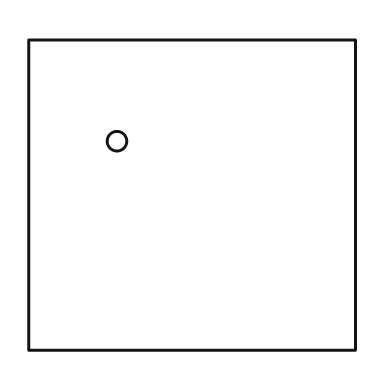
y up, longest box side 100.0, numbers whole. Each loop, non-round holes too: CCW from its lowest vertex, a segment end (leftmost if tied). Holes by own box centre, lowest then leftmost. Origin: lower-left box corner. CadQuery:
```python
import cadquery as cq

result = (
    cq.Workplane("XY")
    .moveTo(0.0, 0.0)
    .lineTo(100.0, 0.0)
    .lineTo(100.0, 95.0)
    .lineTo(0.0, 95.0)
    .close()
    .moveTo(27.0, 64.0)
    .circle(3.0)
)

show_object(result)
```